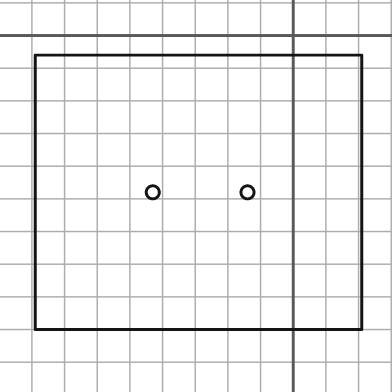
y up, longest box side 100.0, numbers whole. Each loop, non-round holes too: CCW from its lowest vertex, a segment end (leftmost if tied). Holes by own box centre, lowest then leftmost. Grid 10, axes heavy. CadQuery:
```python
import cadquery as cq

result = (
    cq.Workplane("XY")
    .moveTo(-79.0, -90.0)
    .lineTo(21.0, -90.0)
    .lineTo(21.0, -6.0)
    .lineTo(-79.0, -6.0)
    .close()
    .moveTo(-43.0, -48.0)
    .circle(2.0)
    .moveTo(-14.0, -48.0)
    .circle(2.0)
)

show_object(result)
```